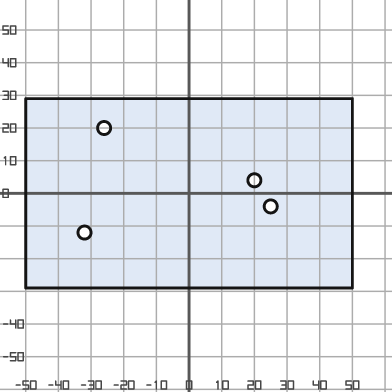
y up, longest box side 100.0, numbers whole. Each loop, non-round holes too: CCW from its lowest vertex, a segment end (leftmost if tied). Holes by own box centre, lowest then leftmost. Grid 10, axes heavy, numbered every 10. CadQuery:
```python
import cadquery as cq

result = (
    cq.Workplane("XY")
    .moveTo(-50.0, -29.0)
    .lineTo(50.0, -29.0)
    .lineTo(50.0, 29.0)
    .lineTo(-50.0, 29.0)
    .close()
    .moveTo(-32.0, -12.0)
    .circle(2.0)
    .moveTo(25.0, -4.0)
    .circle(2.0)
    .moveTo(20.0, 4.0)
    .circle(2.0)
    .moveTo(-26.0, 20.0)
    .circle(2.0)
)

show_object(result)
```